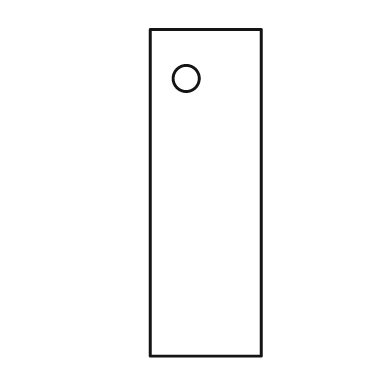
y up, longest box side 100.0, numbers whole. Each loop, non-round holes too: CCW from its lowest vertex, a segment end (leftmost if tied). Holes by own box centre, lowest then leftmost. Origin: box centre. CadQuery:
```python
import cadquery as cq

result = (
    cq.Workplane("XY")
    .moveTo(-17.0, -50.0)
    .lineTo(17.0, -50.0)
    .lineTo(17.0, 50.0)
    .lineTo(-17.0, 50.0)
    .close()
    .moveTo(-6.0, 35.0)
    .circle(4.0)
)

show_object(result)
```